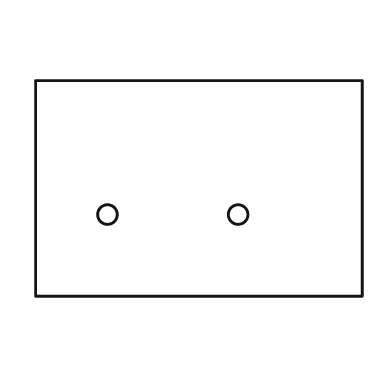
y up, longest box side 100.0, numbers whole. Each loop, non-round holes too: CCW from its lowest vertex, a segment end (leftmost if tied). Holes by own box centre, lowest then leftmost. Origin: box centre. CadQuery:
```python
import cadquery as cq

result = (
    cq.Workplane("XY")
    .moveTo(-50.0, -33.0)
    .lineTo(50.0, -33.0)
    .lineTo(50.0, 33.0)
    .lineTo(-50.0, 33.0)
    .close()
    .moveTo(-28.0, -8.0)
    .circle(3.0)
    .moveTo(12.0, -8.0)
    .circle(3.0)
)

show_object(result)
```